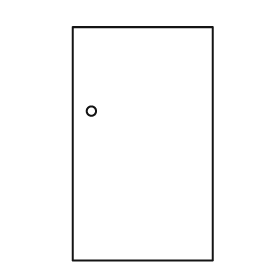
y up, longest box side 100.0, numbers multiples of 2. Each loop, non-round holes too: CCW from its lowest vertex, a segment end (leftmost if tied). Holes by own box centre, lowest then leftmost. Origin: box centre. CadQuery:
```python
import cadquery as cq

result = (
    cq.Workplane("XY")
    .moveTo(-30.0, -50.0)
    .lineTo(30.0, -50.0)
    .lineTo(30.0, 50.0)
    .lineTo(-30.0, 50.0)
    .close()
    .moveTo(-22.0, 14.0)
    .circle(2.0)
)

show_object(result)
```